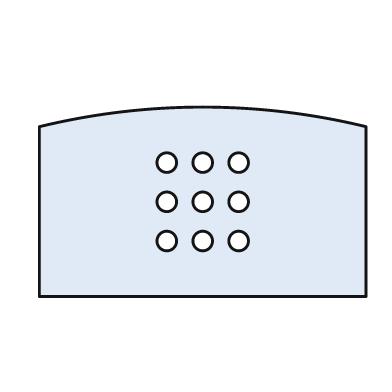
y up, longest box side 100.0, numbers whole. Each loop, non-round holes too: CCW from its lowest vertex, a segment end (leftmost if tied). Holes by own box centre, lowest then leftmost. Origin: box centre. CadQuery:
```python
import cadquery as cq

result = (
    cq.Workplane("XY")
    .moveTo(-50.0, -29.0)
    .lineTo(50.0, -29.0)
    .lineTo(50.0, 23.0)
    .threePointArc((0.0, 29.0), (-50.0, 23.0))
    .close()
    .moveTo(-11.0, -12.0)
    .circle(3.0)
    .moveTo(0.0, -12.0)
    .circle(3.0)
    .moveTo(11.0, -12.0)
    .circle(3.0)
    .moveTo(-11.0, 0.0)
    .circle(3.0)
    .moveTo(0.0, 0.0)
    .circle(3.0)
    .moveTo(11.0, 0.0)
    .circle(3.0)
    .moveTo(-11.0, 12.0)
    .circle(3.0)
    .moveTo(0.0, 12.0)
    .circle(3.0)
    .moveTo(11.0, 12.0)
    .circle(3.0)
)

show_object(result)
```